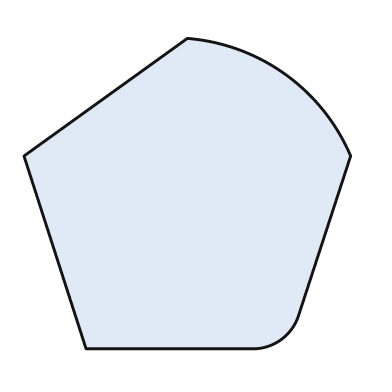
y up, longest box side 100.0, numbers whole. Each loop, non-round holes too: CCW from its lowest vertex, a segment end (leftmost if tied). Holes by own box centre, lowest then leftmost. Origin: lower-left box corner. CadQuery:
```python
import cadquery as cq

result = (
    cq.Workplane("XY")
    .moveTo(19.0, 0.0)
    .lineTo(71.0, 0.0)
    .threePointArc((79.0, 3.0), (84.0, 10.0))
    .lineTo(100.0, 59.0)
    .threePointArc((80.0, 84.0), (50.0, 95.0))
    .lineTo(0.0, 59.0)
    .close()
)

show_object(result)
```